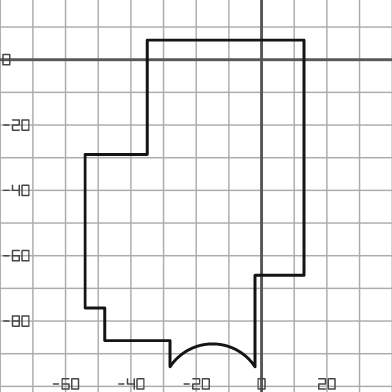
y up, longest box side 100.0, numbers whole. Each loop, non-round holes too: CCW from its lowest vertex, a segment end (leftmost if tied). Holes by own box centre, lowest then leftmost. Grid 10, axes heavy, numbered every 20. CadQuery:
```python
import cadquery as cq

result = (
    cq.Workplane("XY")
    .moveTo(-28.0, -94.0)
    .threePointArc((-15.0, -87.0), (-2.0, -94.0))
    .lineTo(-2.0, -66.0)
    .lineTo(13.0, -66.0)
    .lineTo(13.0, 6.0)
    .lineTo(-35.0, 6.0)
    .lineTo(-35.0, -29.0)
    .lineTo(-54.0, -29.0)
    .lineTo(-54.0, -76.0)
    .lineTo(-48.0, -76.0)
    .lineTo(-48.0, -86.0)
    .lineTo(-28.0, -86.0)
    .close()
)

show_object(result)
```